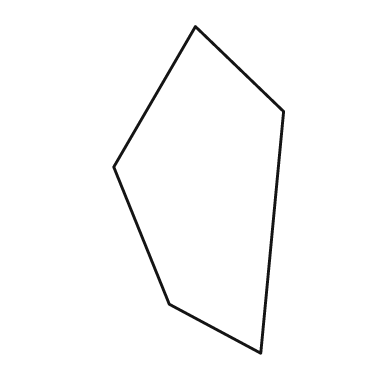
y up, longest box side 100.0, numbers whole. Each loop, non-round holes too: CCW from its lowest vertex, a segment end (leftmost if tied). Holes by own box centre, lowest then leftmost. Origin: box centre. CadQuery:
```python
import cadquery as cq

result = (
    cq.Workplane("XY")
    .moveTo(19.0, -50.0)
    .lineTo(26.0, 24.0)
    .lineTo(-1.0, 50.0)
    .lineTo(-26.0, 7.0)
    .lineTo(-9.0, -35.0)
    .close()
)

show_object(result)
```